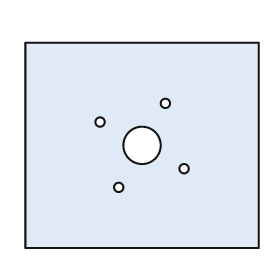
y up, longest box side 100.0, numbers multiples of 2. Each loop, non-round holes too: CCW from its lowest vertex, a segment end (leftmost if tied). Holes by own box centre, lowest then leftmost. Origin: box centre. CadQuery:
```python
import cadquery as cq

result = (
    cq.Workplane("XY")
    .moveTo(-50.0, -44.0)
    .lineTo(50.0, -44.0)
    .lineTo(50.0, 44.0)
    .lineTo(-50.0, 44.0)
    .close()
    .moveTo(-10.0, -18.0)
    .circle(2.0)
    .moveTo(18.0, -10.0)
    .circle(2.0)
    .moveTo(0.0, 0.0)
    .circle(8.0)
    .moveTo(-18.0, 10.0)
    .circle(2.0)
    .moveTo(10.0, 18.0)
    .circle(2.0)
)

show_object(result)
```